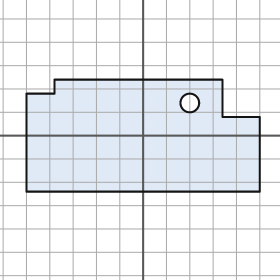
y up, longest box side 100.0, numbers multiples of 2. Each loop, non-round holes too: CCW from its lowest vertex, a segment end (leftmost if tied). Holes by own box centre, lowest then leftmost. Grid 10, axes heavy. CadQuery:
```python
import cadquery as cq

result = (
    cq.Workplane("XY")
    .moveTo(-50.0, -24.0)
    .lineTo(50.0, -24.0)
    .lineTo(50.0, 8.0)
    .lineTo(34.0, 8.0)
    .lineTo(34.0, 24.0)
    .lineTo(-38.0, 24.0)
    .lineTo(-38.0, 18.0)
    .lineTo(-50.0, 18.0)
    .close()
    .moveTo(20.0, 14.0)
    .circle(4.0)
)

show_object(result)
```